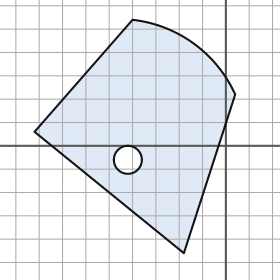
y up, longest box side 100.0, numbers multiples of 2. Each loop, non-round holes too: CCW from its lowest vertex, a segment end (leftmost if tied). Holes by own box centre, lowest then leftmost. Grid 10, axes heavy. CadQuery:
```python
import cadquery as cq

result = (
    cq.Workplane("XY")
    .moveTo(-18.0, -46.0)
    .lineTo(4.0, 22.0)
    .threePointArc((-14.0, 44.0), (-40.0, 54.0))
    .lineTo(-82.0, 6.0)
    .close()
    .moveTo(-42.0, -6.0)
    .circle(6.0)
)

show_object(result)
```